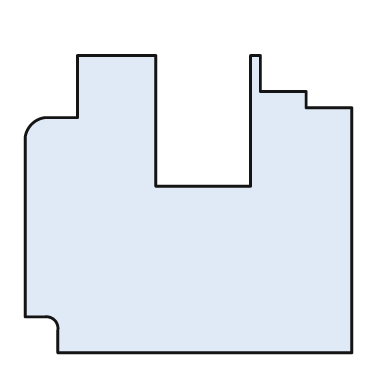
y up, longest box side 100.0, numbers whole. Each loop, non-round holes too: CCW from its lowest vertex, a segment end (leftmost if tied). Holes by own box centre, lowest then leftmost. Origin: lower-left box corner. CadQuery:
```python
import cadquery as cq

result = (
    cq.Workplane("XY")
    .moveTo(10.0, 0.0)
    .lineTo(100.0, 0.0)
    .lineTo(100.0, 75.0)
    .lineTo(86.0, 75.0)
    .lineTo(86.0, 80.0)
    .lineTo(72.0, 80.0)
    .lineTo(72.0, 91.0)
    .lineTo(69.0, 91.0)
    .lineTo(69.0, 51.0)
    .lineTo(40.0, 51.0)
    .lineTo(40.0, 91.0)
    .lineTo(16.0, 91.0)
    .lineTo(16.0, 72.0)
    .lineTo(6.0, 72.0)
    .threePointArc((2.0, 70.0), (0.0, 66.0))
    .lineTo(0.0, 11.0)
    .lineTo(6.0, 11.0)
    .threePointArc((9.0, 10.0), (10.0, 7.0))
    .close()
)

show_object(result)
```